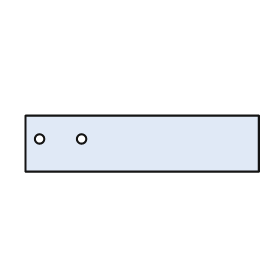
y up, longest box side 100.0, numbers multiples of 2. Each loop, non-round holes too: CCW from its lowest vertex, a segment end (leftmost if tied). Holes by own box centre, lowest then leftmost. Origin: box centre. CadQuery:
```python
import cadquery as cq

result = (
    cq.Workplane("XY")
    .moveTo(-50.0, -12.0)
    .lineTo(50.0, -12.0)
    .lineTo(50.0, 12.0)
    .lineTo(-50.0, 12.0)
    .close()
    .moveTo(-44.0, 2.0)
    .circle(2.0)
    .moveTo(-26.0, 2.0)
    .circle(2.0)
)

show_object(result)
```